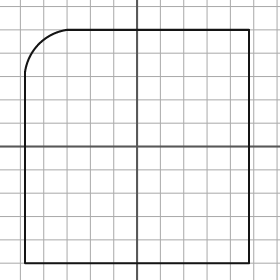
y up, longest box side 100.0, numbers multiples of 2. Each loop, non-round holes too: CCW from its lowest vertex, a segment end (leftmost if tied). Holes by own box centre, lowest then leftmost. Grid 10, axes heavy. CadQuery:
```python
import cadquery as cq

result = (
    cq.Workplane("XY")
    .moveTo(-48.0, -50.0)
    .lineTo(48.0, -50.0)
    .lineTo(48.0, 50.0)
    .lineTo(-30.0, 50.0)
    .threePointArc((-42.0, 44.0), (-48.0, 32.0))
    .close()
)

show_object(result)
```